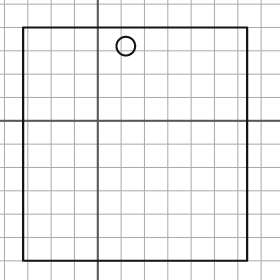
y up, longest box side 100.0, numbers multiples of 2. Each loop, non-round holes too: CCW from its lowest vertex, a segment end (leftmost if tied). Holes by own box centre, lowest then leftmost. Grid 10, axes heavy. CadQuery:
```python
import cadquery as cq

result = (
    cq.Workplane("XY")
    .moveTo(-32.0, -60.0)
    .lineTo(64.0, -60.0)
    .lineTo(64.0, 40.0)
    .lineTo(-32.0, 40.0)
    .close()
    .moveTo(12.0, 32.0)
    .circle(4.0)
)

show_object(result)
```